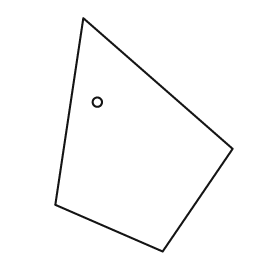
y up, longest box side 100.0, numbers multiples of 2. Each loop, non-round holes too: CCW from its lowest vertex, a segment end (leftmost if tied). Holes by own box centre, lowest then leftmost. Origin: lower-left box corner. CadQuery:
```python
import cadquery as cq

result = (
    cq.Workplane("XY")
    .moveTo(46.0, 0.0)
    .lineTo(76.0, 44.0)
    .lineTo(12.0, 100.0)
    .lineTo(0.0, 20.0)
    .close()
    .moveTo(18.0, 64.0)
    .circle(2.0)
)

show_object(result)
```